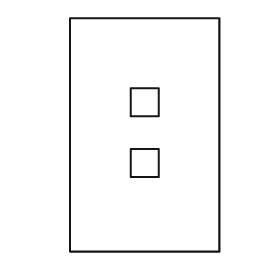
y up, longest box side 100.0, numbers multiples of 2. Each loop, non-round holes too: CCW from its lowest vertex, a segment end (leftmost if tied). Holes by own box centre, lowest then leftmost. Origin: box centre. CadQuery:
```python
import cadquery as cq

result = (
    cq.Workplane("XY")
    .moveTo(-32.0, -50.0)
    .lineTo(32.0, -50.0)
    .lineTo(32.0, 50.0)
    .lineTo(-32.0, 50.0)
    .close()
    .moveTo(-6.0, -18.0)
    .lineTo(6.0, -18.0)
    .lineTo(6.0, -6.0)
    .lineTo(-6.0, -6.0)
    .close()
    .moveTo(-6.0, 8.0)
    .lineTo(6.0, 8.0)
    .lineTo(6.0, 20.0)
    .lineTo(-6.0, 20.0)
    .close()
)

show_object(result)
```